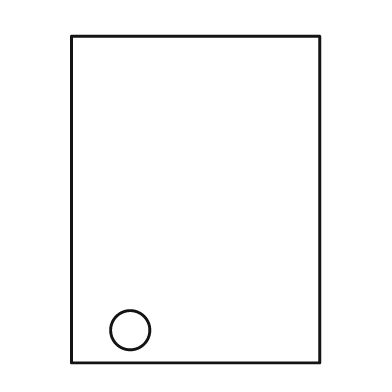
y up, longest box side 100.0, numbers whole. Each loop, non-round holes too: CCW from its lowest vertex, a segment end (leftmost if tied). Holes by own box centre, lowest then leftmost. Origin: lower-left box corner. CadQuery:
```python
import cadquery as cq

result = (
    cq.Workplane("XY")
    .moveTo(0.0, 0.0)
    .lineTo(76.0, 0.0)
    .lineTo(76.0, 100.0)
    .lineTo(0.0, 100.0)
    .close()
    .moveTo(18.0, 10.0)
    .circle(6.0)
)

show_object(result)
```